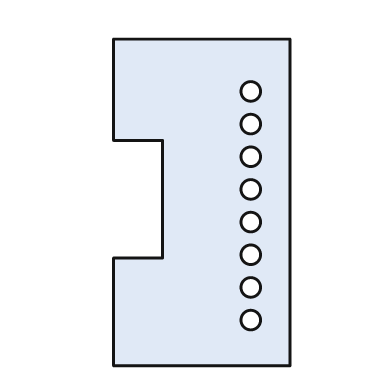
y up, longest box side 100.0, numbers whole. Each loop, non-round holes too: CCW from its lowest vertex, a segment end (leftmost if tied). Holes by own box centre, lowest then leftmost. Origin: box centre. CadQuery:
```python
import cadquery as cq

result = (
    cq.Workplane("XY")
    .moveTo(-27.0, -50.0)
    .lineTo(27.0, -50.0)
    .lineTo(27.0, 50.0)
    .lineTo(-27.0, 50.0)
    .lineTo(-27.0, 19.0)
    .lineTo(-12.0, 19.0)
    .lineTo(-12.0, -17.0)
    .lineTo(-27.0, -17.0)
    .close()
    .moveTo(15.0, -36.0)
    .circle(3.0)
    .moveTo(15.0, -26.0)
    .circle(3.0)
    .moveTo(15.0, -16.0)
    .circle(3.0)
    .moveTo(15.0, -6.0)
    .circle(3.0)
    .moveTo(15.0, 4.0)
    .circle(3.0)
    .moveTo(15.0, 14.0)
    .circle(3.0)
    .moveTo(15.0, 24.0)
    .circle(3.0)
    .moveTo(15.0, 34.0)
    .circle(3.0)
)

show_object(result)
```